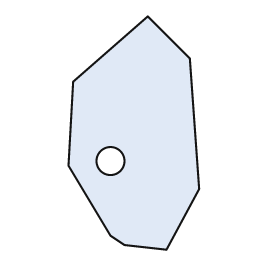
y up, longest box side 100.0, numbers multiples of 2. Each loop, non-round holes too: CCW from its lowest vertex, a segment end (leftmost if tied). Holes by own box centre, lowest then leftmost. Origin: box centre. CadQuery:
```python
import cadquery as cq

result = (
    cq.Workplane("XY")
    .moveTo(14.0, -50.0)
    .lineTo(28.0, -24.0)
    .lineTo(24.0, 32.0)
    .lineTo(6.0, 50.0)
    .lineTo(-26.0, 22.0)
    .lineTo(-28.0, -14.0)
    .lineTo(-10.0, -44.0)
    .lineTo(-4.0, -48.0)
    .close()
    .moveTo(-10.0, -12.0)
    .circle(6.0)
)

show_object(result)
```